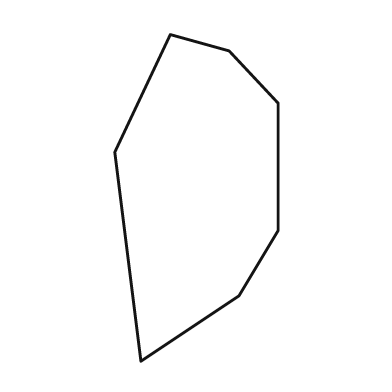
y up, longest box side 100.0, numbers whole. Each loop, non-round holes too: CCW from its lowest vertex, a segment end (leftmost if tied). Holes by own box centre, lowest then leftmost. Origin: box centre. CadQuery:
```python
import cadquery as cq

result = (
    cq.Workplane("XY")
    .moveTo(-17.0, -50.0)
    .lineTo(13.0, -30.0)
    .lineTo(25.0, -10.0)
    .lineTo(25.0, 29.0)
    .lineTo(10.0, 45.0)
    .lineTo(-8.0, 50.0)
    .lineTo(-25.0, 14.0)
    .close()
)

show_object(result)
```